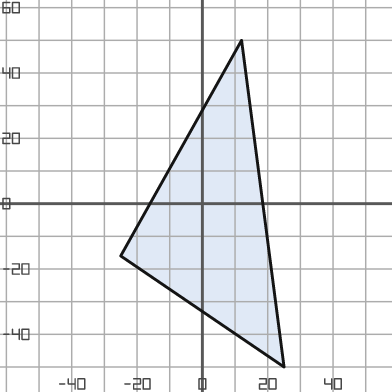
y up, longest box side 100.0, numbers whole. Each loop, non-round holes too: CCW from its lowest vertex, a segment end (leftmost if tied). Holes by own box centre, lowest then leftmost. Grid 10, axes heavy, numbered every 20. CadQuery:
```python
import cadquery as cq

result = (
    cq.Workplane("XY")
    .moveTo(25.0, -50.0)
    .lineTo(12.0, 50.0)
    .lineTo(-25.0, -16.0)
    .close()
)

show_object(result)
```